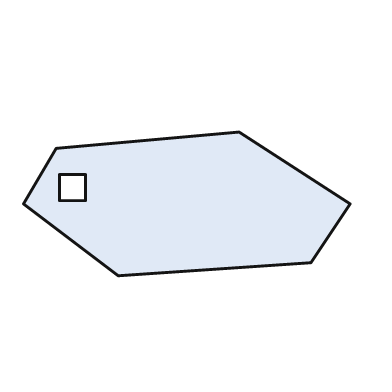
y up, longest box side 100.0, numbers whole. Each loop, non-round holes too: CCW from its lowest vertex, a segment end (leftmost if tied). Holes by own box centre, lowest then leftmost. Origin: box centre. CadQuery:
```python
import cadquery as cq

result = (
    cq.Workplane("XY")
    .moveTo(-21.0, -22.0)
    .lineTo(38.0, -18.0)
    .lineTo(50.0, 0.0)
    .lineTo(16.0, 22.0)
    .lineTo(-40.0, 17.0)
    .lineTo(-50.0, 0.0)
    .close()
    .moveTo(-39.0, 1.0)
    .lineTo(-31.0, 1.0)
    .lineTo(-31.0, 9.0)
    .lineTo(-39.0, 9.0)
    .close()
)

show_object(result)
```